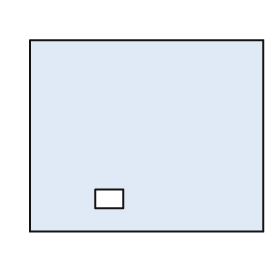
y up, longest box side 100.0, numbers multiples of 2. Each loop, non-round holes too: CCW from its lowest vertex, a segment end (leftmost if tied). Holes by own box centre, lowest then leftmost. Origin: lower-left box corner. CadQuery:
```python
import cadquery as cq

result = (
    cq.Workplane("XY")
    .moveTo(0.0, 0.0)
    .lineTo(100.0, 0.0)
    .lineTo(100.0, 82.0)
    .lineTo(0.0, 82.0)
    .close()
    .moveTo(28.0, 10.0)
    .lineTo(40.0, 10.0)
    .lineTo(40.0, 18.0)
    .lineTo(28.0, 18.0)
    .close()
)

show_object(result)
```